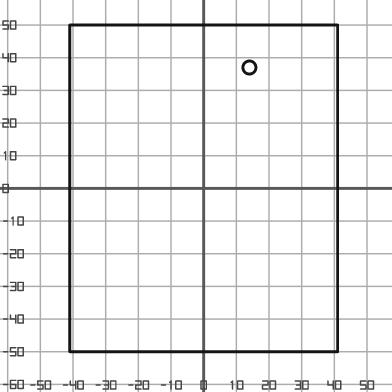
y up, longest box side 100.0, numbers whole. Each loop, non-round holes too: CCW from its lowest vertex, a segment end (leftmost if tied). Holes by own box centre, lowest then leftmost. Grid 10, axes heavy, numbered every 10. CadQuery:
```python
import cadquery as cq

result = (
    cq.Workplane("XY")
    .moveTo(-41.0, -50.0)
    .lineTo(41.0, -50.0)
    .lineTo(41.0, 50.0)
    .lineTo(-41.0, 50.0)
    .close()
    .moveTo(14.0, 37.0)
    .circle(2.0)
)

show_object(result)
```